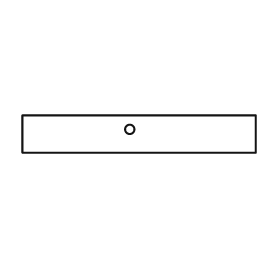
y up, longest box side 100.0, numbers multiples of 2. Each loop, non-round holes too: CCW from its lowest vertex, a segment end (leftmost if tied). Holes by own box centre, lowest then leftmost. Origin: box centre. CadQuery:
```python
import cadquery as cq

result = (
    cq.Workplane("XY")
    .moveTo(-50.0, -8.0)
    .lineTo(50.0, -8.0)
    .lineTo(50.0, 8.0)
    .lineTo(-50.0, 8.0)
    .close()
    .moveTo(-4.0, 2.0)
    .circle(2.0)
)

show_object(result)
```